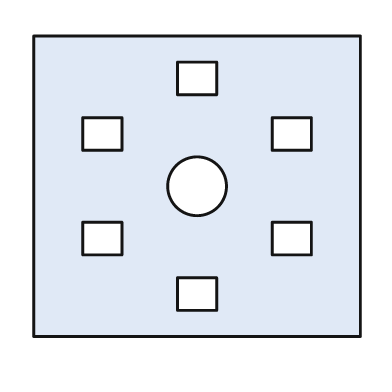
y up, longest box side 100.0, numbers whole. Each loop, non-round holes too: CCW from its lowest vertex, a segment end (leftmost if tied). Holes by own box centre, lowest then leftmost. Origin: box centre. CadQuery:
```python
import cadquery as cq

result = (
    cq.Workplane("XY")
    .moveTo(-50.0, -46.0)
    .lineTo(50.0, -46.0)
    .lineTo(50.0, 46.0)
    .lineTo(-50.0, 46.0)
    .close()
    .moveTo(-6.0, -38.0)
    .lineTo(6.0, -38.0)
    .lineTo(6.0, -28.0)
    .lineTo(-6.0, -28.0)
    .close()
    .moveTo(-35.0, -21.0)
    .lineTo(-23.0, -21.0)
    .lineTo(-23.0, -11.0)
    .lineTo(-35.0, -11.0)
    .close()
    .moveTo(23.0, -21.0)
    .lineTo(35.0, -21.0)
    .lineTo(35.0, -11.0)
    .lineTo(23.0, -11.0)
    .close()
    .moveTo(0.0, 0.0)
    .circle(9.0)
    .moveTo(-35.0, 11.0)
    .lineTo(-23.0, 11.0)
    .lineTo(-23.0, 21.0)
    .lineTo(-35.0, 21.0)
    .close()
    .moveTo(23.0, 11.0)
    .lineTo(35.0, 11.0)
    .lineTo(35.0, 21.0)
    .lineTo(23.0, 21.0)
    .close()
    .moveTo(-6.0, 28.0)
    .lineTo(6.0, 28.0)
    .lineTo(6.0, 38.0)
    .lineTo(-6.0, 38.0)
    .close()
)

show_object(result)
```